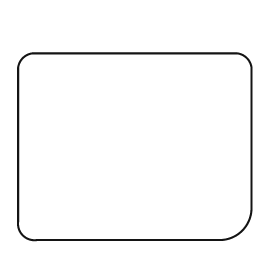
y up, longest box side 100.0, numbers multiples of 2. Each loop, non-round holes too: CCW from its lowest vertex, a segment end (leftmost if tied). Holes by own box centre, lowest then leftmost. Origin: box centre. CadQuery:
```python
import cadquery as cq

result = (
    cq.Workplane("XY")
    .moveTo(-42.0, -40.0)
    .lineTo(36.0, -40.0)
    .threePointArc((46.0, -36.0), (50.0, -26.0))
    .lineTo(50.0, 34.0)
    .threePointArc((48.0, 38.0), (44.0, 40.0))
    .lineTo(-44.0, 40.0)
    .threePointArc((-48.0, 38.0), (-50.0, 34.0))
    .lineTo(-50.0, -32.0)
    .threePointArc((-48.0, -38.0), (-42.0, -40.0))
    .close()
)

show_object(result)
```